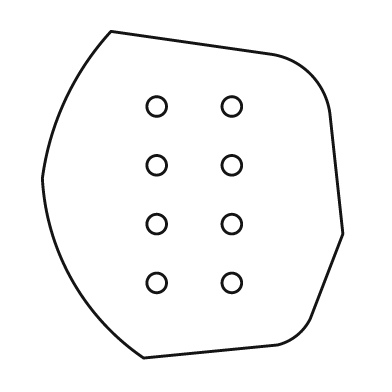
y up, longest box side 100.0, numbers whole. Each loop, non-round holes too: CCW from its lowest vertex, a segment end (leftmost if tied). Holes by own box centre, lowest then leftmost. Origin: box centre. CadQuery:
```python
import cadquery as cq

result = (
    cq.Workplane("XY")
    .moveTo(-15.0, -50.0)
    .lineTo(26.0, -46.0)
    .threePointArc((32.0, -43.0), (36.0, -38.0))
    .lineTo(46.0, -12.0)
    .lineTo(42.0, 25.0)
    .threePointArc((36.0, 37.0), (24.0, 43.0))
    .lineTo(-25.0, 50.0)
    .threePointArc((-39.0, 29.0), (-46.0, 5.0))
    .threePointArc((-37.0, -26.0), (-15.0, -50.0))
    .close()
    .moveTo(-11.0, -27.0)
    .circle(3.0)
    .moveTo(12.0, -27.0)
    .circle(3.0)
    .moveTo(-11.0, -9.0)
    .circle(3.0)
    .moveTo(12.0, -9.0)
    .circle(3.0)
    .moveTo(-11.0, 9.0)
    .circle(3.0)
    .moveTo(12.0, 9.0)
    .circle(3.0)
    .moveTo(-11.0, 27.0)
    .circle(3.0)
    .moveTo(12.0, 27.0)
    .circle(3.0)
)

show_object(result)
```